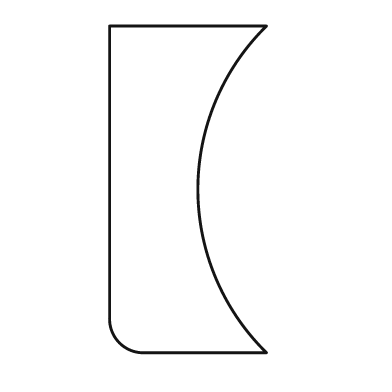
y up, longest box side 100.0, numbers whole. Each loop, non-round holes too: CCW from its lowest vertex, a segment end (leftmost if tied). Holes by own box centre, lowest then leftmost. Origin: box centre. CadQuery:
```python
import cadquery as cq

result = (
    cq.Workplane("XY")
    .moveTo(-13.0, -50.0)
    .lineTo(24.0, -50.0)
    .threePointArc((3.0, 0.0), (24.0, 50.0))
    .lineTo(-24.0, 50.0)
    .lineTo(-24.0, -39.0)
    .threePointArc((-21.0, -47.0), (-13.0, -50.0))
    .close()
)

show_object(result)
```